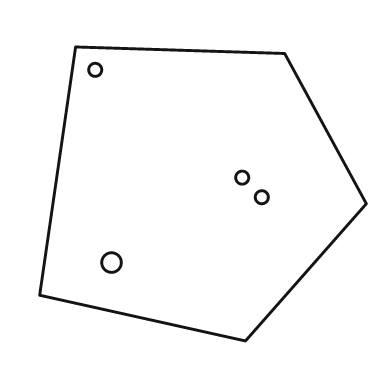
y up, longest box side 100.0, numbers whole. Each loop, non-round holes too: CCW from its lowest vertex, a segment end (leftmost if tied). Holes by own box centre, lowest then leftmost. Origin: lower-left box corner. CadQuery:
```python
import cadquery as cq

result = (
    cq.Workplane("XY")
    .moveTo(63.0, 0.0)
    .lineTo(100.0, 42.0)
    .lineTo(75.0, 88.0)
    .lineTo(11.0, 90.0)
    .lineTo(0.0, 14.0)
    .close()
    .moveTo(22.0, 24.0)
    .circle(3.0)
    .moveTo(68.0, 44.0)
    .circle(2.0)
    .moveTo(62.0, 50.0)
    .circle(2.0)
    .moveTo(17.0, 83.0)
    .circle(2.0)
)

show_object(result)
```